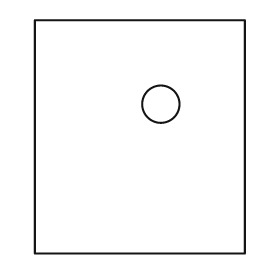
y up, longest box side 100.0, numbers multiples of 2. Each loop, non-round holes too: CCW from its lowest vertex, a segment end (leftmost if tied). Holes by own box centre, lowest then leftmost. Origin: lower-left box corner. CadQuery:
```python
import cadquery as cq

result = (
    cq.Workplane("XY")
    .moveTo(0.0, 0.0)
    .lineTo(90.0, 0.0)
    .lineTo(90.0, 100.0)
    .lineTo(0.0, 100.0)
    .close()
    .moveTo(54.0, 64.0)
    .circle(8.0)
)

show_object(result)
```